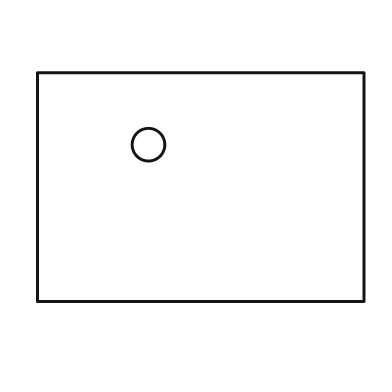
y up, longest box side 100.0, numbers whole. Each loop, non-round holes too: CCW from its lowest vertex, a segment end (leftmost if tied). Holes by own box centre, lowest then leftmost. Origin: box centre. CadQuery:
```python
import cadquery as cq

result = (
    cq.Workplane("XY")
    .moveTo(-50.0, -35.0)
    .lineTo(50.0, -35.0)
    .lineTo(50.0, 35.0)
    .lineTo(-50.0, 35.0)
    .close()
    .moveTo(-16.0, 13.0)
    .circle(5.0)
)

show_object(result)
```